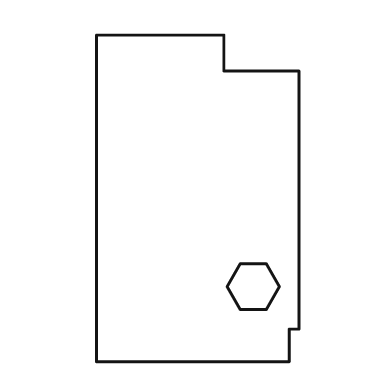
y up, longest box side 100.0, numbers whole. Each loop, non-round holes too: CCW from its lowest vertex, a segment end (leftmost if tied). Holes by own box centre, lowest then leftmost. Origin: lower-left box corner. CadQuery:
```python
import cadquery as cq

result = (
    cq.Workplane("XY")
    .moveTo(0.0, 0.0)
    .lineTo(59.0, 0.0)
    .lineTo(59.0, 10.0)
    .lineTo(62.0, 10.0)
    .lineTo(62.0, 89.0)
    .lineTo(39.0, 89.0)
    .lineTo(39.0, 100.0)
    .lineTo(0.0, 100.0)
    .close()
    .moveTo(44.0, 16.0)
    .lineTo(52.0, 16.0)
    .lineTo(56.0, 23.0)
    .lineTo(52.0, 30.0)
    .lineTo(44.0, 30.0)
    .lineTo(40.0, 23.0)
    .close()
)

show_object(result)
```